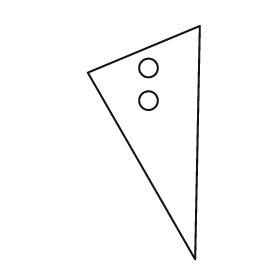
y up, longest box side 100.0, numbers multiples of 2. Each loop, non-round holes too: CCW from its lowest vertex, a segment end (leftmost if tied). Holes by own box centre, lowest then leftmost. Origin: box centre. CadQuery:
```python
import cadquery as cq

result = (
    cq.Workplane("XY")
    .moveTo(22.0, -50.0)
    .lineTo(24.0, 50.0)
    .lineTo(-24.0, 30.0)
    .close()
    .moveTo(2.0, 18.0)
    .circle(4.0)
    .moveTo(2.0, 32.0)
    .circle(4.0)
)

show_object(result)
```